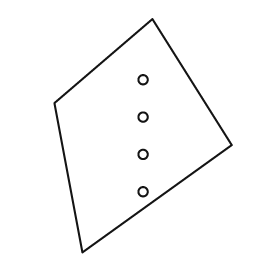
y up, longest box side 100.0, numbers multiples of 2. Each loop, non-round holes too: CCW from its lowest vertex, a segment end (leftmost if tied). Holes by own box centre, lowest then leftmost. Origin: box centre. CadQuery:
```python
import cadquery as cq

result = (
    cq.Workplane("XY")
    .moveTo(-26.0, -50.0)
    .lineTo(38.0, -4.0)
    .lineTo(4.0, 50.0)
    .lineTo(-38.0, 14.0)
    .close()
    .moveTo(0.0, -24.0)
    .circle(2.0)
    .moveTo(0.0, -8.0)
    .circle(2.0)
    .moveTo(0.0, 8.0)
    .circle(2.0)
    .moveTo(0.0, 24.0)
    .circle(2.0)
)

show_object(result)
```